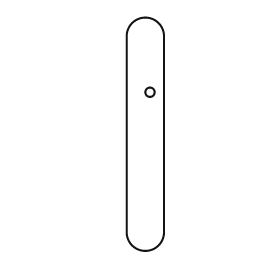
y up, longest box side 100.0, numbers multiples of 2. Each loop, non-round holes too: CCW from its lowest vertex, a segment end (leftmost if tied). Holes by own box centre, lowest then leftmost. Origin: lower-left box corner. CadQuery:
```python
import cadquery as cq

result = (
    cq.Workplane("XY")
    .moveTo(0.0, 8.0)
    .threePointArc((8.0, 0.0), (16.0, 8.0))
    .lineTo(16.0, 92.0)
    .threePointArc((8.0, 100.0), (0.0, 92.0))
    .close()
    .moveTo(10.0, 68.0)
    .circle(2.0)
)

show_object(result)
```